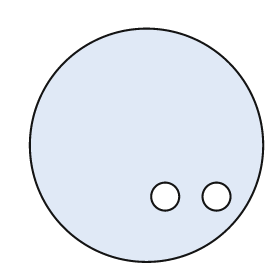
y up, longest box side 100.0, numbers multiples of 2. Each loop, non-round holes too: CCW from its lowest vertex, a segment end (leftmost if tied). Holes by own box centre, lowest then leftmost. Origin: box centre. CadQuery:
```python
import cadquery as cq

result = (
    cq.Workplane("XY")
    .moveTo(0.0, 0.0)
    .circle(50.0)
    .moveTo(8.0, -22.0)
    .circle(6.0)
    .moveTo(30.0, -22.0)
    .circle(6.0)
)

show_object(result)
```